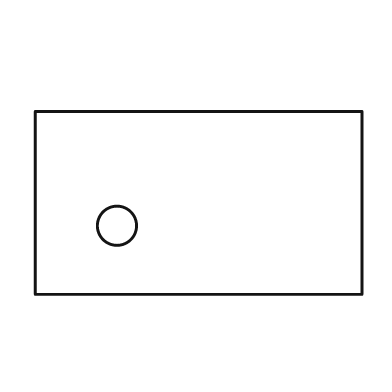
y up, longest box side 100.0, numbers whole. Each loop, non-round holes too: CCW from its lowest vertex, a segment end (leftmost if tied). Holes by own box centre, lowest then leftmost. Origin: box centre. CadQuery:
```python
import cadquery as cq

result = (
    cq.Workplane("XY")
    .moveTo(-50.0, -28.0)
    .lineTo(50.0, -28.0)
    .lineTo(50.0, 28.0)
    .lineTo(-50.0, 28.0)
    .close()
    .moveTo(-25.0, -7.0)
    .circle(6.0)
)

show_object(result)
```